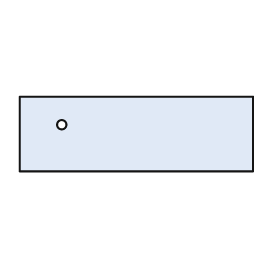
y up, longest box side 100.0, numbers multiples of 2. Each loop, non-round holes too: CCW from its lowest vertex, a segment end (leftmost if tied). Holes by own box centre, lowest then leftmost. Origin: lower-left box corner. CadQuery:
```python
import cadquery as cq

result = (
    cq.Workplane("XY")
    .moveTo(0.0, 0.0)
    .lineTo(100.0, 0.0)
    .lineTo(100.0, 32.0)
    .lineTo(0.0, 32.0)
    .close()
    .moveTo(18.0, 20.0)
    .circle(2.0)
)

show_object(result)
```